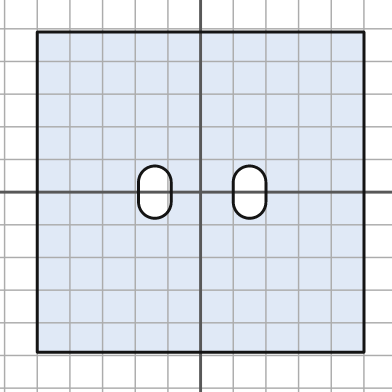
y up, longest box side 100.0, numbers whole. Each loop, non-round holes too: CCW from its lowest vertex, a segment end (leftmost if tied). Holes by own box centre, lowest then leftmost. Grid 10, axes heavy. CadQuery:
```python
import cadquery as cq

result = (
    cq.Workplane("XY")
    .moveTo(-50.0, -49.0)
    .lineTo(50.0, -49.0)
    .lineTo(50.0, 49.0)
    .lineTo(-50.0, 49.0)
    .close()
    .moveTo(-19.0, -3.0)
    .threePointArc((-14.0, -8.0), (-9.0, -3.0))
    .lineTo(-9.0, 3.0)
    .threePointArc((-14.0, 8.0), (-19.0, 3.0))
    .close()
    .moveTo(10.0, -3.0)
    .threePointArc((15.0, -8.0), (20.0, -3.0))
    .lineTo(20.0, 3.0)
    .threePointArc((15.0, 8.0), (10.0, 3.0))
    .close()
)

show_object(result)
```